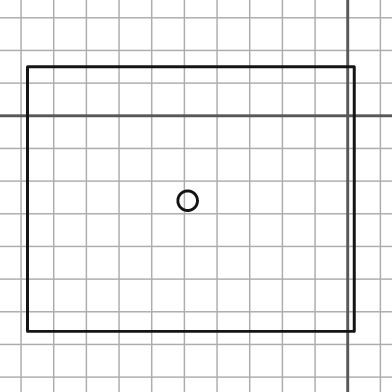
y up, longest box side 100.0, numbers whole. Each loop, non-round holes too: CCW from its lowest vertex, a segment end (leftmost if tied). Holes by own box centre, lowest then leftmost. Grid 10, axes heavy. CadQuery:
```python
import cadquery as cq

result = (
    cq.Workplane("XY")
    .moveTo(-98.0, -66.0)
    .lineTo(2.0, -66.0)
    .lineTo(2.0, 15.0)
    .lineTo(-98.0, 15.0)
    .close()
    .moveTo(-49.0, -26.0)
    .circle(3.0)
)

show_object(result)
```